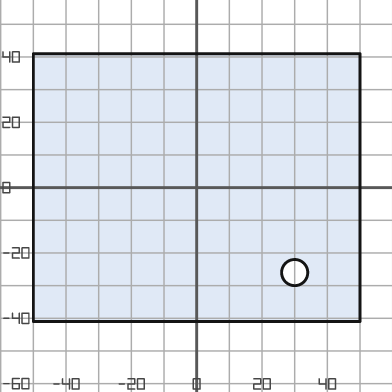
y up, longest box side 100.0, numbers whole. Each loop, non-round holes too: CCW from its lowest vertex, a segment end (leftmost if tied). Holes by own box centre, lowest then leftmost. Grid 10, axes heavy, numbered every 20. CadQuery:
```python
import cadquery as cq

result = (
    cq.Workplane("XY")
    .moveTo(-50.0, -41.0)
    .lineTo(50.0, -41.0)
    .lineTo(50.0, 41.0)
    .lineTo(-50.0, 41.0)
    .close()
    .moveTo(30.0, -26.0)
    .circle(4.0)
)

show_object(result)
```